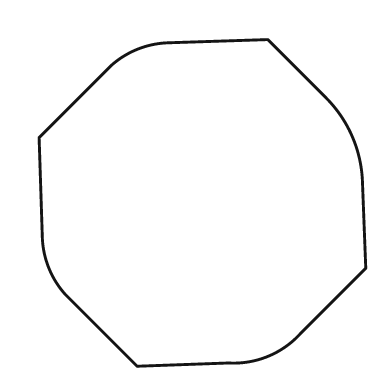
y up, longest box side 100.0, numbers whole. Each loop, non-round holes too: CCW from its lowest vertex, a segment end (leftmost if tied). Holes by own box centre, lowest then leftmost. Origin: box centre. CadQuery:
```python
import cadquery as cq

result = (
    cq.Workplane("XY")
    .moveTo(-20.0, -50.0)
    .lineTo(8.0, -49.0)
    .threePointArc((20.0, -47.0), (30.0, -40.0))
    .lineTo(50.0, -20.0)
    .lineTo(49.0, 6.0)
    .threePointArc((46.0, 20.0), (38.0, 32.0))
    .lineTo(20.0, 50.0)
    .lineTo(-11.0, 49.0)
    .threePointArc((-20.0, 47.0), (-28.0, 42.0))
    .lineTo(-50.0, 20.0)
    .lineTo(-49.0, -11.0)
    .threePointArc((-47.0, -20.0), (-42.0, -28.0))
    .close()
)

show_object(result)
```